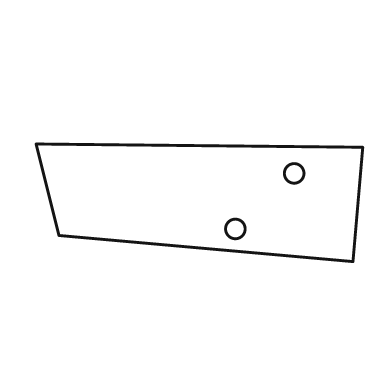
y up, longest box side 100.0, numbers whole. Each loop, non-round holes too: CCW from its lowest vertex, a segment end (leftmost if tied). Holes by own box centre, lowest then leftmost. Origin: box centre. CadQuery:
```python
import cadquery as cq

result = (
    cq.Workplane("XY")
    .moveTo(47.0, -18.0)
    .lineTo(50.0, 17.0)
    .lineTo(-50.0, 18.0)
    .lineTo(-43.0, -10.0)
    .close()
    .moveTo(11.0, -8.0)
    .circle(3.0)
    .moveTo(29.0, 9.0)
    .circle(3.0)
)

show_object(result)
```